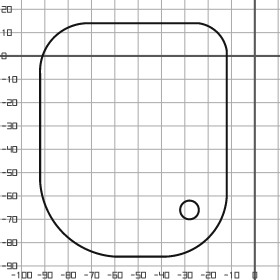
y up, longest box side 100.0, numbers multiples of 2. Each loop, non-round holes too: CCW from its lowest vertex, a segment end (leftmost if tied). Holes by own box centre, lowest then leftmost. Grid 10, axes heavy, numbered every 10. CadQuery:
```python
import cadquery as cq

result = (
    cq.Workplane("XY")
    .moveTo(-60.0, -86.0)
    .lineTo(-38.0, -86.0)
    .threePointArc((-20.0, -78.0), (-12.0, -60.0))
    .lineTo(-12.0, 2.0)
    .threePointArc((-16.0, 10.0), (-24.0, 14.0))
    .lineTo(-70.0, 14.0)
    .threePointArc((-86.0, 8.0), (-92.0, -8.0))
    .lineTo(-92.0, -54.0)
    .threePointArc((-82.0, -76.0), (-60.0, -86.0))
    .close()
    .moveTo(-28.0, -66.0)
    .circle(4.0)
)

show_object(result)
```